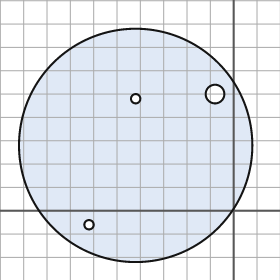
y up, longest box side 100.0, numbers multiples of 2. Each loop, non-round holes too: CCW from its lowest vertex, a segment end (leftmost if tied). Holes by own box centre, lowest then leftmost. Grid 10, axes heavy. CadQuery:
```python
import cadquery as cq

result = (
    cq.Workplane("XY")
    .moveTo(-42.0, 28.0)
    .circle(50.0)
    .moveTo(-62.0, -6.0)
    .circle(2.0)
    .moveTo(-42.0, 48.0)
    .circle(2.0)
    .moveTo(-8.0, 50.0)
    .circle(4.0)
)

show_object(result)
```